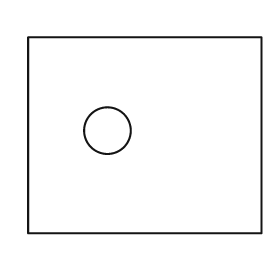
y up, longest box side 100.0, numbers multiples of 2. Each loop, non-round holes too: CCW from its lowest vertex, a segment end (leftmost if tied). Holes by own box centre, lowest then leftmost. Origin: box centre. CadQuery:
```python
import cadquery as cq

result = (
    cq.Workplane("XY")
    .moveTo(-50.0, -42.0)
    .lineTo(50.0, -42.0)
    .lineTo(50.0, 42.0)
    .lineTo(-50.0, 42.0)
    .close()
    .moveTo(-16.0, 2.0)
    .circle(10.0)
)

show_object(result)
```